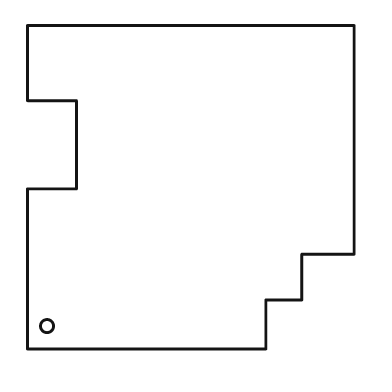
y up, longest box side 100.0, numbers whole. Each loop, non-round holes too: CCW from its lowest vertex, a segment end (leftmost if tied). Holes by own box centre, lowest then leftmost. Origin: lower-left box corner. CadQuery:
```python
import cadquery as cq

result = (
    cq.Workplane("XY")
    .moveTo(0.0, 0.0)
    .lineTo(73.0, 0.0)
    .lineTo(73.0, 15.0)
    .lineTo(84.0, 15.0)
    .lineTo(84.0, 29.0)
    .lineTo(100.0, 29.0)
    .lineTo(100.0, 99.0)
    .lineTo(0.0, 99.0)
    .lineTo(0.0, 76.0)
    .lineTo(15.0, 76.0)
    .lineTo(15.0, 49.0)
    .lineTo(0.0, 49.0)
    .close()
    .moveTo(6.0, 7.0)
    .circle(2.0)
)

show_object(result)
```